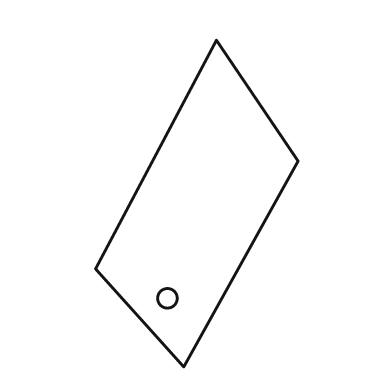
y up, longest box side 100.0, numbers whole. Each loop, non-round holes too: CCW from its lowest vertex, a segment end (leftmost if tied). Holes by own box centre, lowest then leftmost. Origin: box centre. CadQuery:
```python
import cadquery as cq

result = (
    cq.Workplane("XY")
    .moveTo(-4.0, -50.0)
    .lineTo(31.0, 13.0)
    .lineTo(6.0, 50.0)
    .lineTo(-31.0, -20.0)
    .close()
    .moveTo(-9.0, -29.0)
    .circle(3.0)
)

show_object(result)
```